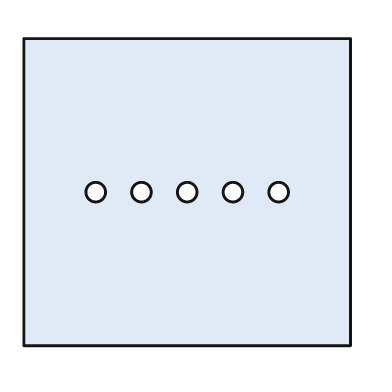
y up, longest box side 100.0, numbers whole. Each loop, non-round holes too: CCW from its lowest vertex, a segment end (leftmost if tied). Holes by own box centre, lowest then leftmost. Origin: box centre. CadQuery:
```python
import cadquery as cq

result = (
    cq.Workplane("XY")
    .moveTo(-50.0, -47.0)
    .lineTo(50.0, -47.0)
    .lineTo(50.0, 47.0)
    .lineTo(-50.0, 47.0)
    .close()
    .moveTo(-28.0, 0.0)
    .circle(3.0)
    .moveTo(-14.0, 0.0)
    .circle(3.0)
    .moveTo(0.0, 0.0)
    .circle(3.0)
    .moveTo(14.0, 0.0)
    .circle(3.0)
    .moveTo(28.0, 0.0)
    .circle(3.0)
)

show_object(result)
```